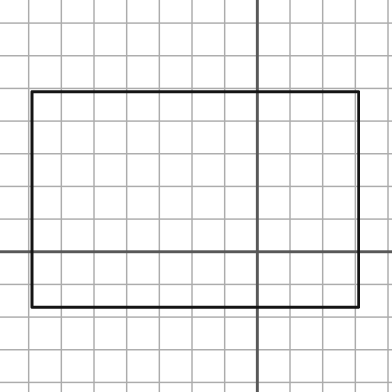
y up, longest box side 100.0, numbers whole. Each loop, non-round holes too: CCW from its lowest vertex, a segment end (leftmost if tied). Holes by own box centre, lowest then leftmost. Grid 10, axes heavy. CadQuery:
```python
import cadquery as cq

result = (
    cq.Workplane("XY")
    .moveTo(-69.0, -17.0)
    .lineTo(31.0, -17.0)
    .lineTo(31.0, 49.0)
    .lineTo(-69.0, 49.0)
    .close()
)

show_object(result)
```